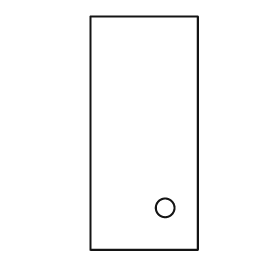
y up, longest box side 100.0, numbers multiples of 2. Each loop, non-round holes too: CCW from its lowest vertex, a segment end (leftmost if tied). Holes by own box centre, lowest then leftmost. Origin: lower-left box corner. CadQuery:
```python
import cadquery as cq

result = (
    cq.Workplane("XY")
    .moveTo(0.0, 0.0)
    .lineTo(46.0, 0.0)
    .lineTo(46.0, 100.0)
    .lineTo(0.0, 100.0)
    .close()
    .moveTo(32.0, 18.0)
    .circle(4.0)
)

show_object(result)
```